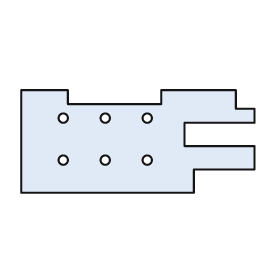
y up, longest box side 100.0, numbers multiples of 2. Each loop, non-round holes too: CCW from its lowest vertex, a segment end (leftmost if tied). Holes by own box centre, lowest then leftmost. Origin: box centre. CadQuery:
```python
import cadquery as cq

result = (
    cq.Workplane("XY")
    .moveTo(-50.0, -22.0)
    .lineTo(24.0, -22.0)
    .lineTo(24.0, -12.0)
    .lineTo(50.0, -12.0)
    .lineTo(50.0, -2.0)
    .lineTo(20.0, -2.0)
    .lineTo(20.0, 8.0)
    .lineTo(50.0, 8.0)
    .lineTo(50.0, 14.0)
    .lineTo(42.0, 14.0)
    .lineTo(42.0, 22.0)
    .lineTo(10.0, 22.0)
    .lineTo(10.0, 16.0)
    .lineTo(-30.0, 16.0)
    .lineTo(-30.0, 22.0)
    .lineTo(-50.0, 22.0)
    .close()
    .moveTo(-32.0, -8.0)
    .circle(2.0)
    .moveTo(-14.0, -8.0)
    .circle(2.0)
    .moveTo(4.0, -8.0)
    .circle(2.0)
    .moveTo(-32.0, 10.0)
    .circle(2.0)
    .moveTo(-14.0, 10.0)
    .circle(2.0)
    .moveTo(4.0, 10.0)
    .circle(2.0)
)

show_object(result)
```